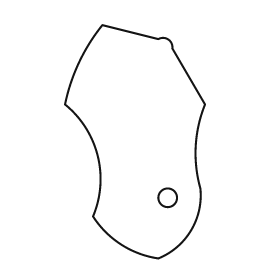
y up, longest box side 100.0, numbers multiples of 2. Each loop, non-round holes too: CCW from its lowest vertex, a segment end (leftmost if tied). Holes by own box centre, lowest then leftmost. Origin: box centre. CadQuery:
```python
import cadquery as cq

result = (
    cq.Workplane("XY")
    .moveTo(10.0, -50.0)
    .threePointArc((24.0, -38.0), (28.0, -20.0))
    .threePointArc((26.0, -2.0), (30.0, 16.0))
    .lineTo(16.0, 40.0)
    .threePointArc((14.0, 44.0), (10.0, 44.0))
    .lineTo(-14.0, 50.0)
    .threePointArc((-24.0, 34.0), (-30.0, 16.0))
    .threePointArc((-16.0, -6.0), (-18.0, -32.0))
    .threePointArc((-6.0, -44.0), (10.0, -50.0))
    .close()
    .moveTo(14.0, -24.0)
    .circle(4.0)
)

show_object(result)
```